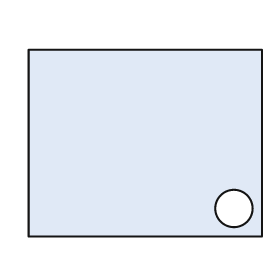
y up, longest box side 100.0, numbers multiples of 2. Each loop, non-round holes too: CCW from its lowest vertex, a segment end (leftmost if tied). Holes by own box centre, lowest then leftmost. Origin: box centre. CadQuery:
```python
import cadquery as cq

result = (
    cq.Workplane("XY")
    .moveTo(-50.0, -40.0)
    .lineTo(50.0, -40.0)
    .lineTo(50.0, 40.0)
    .lineTo(-50.0, 40.0)
    .close()
    .moveTo(38.0, -28.0)
    .circle(8.0)
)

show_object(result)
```